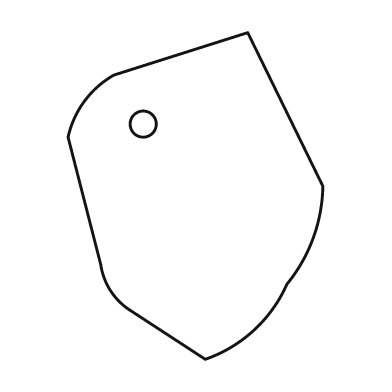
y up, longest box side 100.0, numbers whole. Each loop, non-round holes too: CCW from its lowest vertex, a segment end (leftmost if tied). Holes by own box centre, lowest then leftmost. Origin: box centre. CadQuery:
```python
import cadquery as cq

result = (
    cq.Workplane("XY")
    .moveTo(3.0, -50.0)
    .threePointArc((18.0, -41.0), (28.0, -27.0))
    .threePointArc((36.0, -13.0), (39.0, 3.0))
    .lineTo(16.0, 50.0)
    .lineTo(-25.0, 37.0)
    .threePointArc((-34.0, 29.0), (-39.0, 18.0))
    .lineTo(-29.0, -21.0)
    .threePointArc((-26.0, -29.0), (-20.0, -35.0))
    .close()
    .moveTo(-16.0, 22.0)
    .circle(4.0)
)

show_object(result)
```